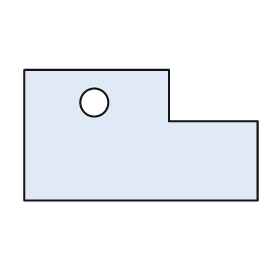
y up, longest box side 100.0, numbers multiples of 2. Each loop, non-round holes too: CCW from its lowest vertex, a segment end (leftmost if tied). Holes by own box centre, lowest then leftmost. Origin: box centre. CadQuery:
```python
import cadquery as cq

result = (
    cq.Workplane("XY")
    .moveTo(-50.0, -28.0)
    .lineTo(50.0, -28.0)
    .lineTo(50.0, 6.0)
    .lineTo(12.0, 6.0)
    .lineTo(12.0, 28.0)
    .lineTo(-50.0, 28.0)
    .close()
    .moveTo(-20.0, 14.0)
    .circle(6.0)
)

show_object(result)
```